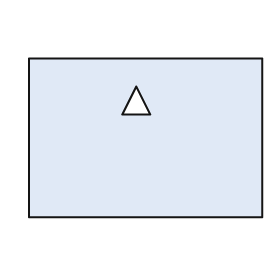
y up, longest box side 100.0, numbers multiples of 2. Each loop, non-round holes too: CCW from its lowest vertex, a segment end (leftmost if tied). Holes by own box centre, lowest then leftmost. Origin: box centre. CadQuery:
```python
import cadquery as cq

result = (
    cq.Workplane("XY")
    .moveTo(-50.0, -34.0)
    .lineTo(50.0, -34.0)
    .lineTo(50.0, 34.0)
    .lineTo(-50.0, 34.0)
    .close()
    .moveTo(-10.0, 10.0)
    .lineTo(2.0, 10.0)
    .lineTo(-4.0, 22.0)
    .close()
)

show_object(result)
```